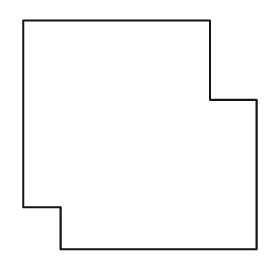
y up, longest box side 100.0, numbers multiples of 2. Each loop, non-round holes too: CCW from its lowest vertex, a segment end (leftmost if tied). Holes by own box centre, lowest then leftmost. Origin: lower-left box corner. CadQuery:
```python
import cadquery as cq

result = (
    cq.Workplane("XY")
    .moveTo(16.0, 0.0)
    .lineTo(100.0, 0.0)
    .lineTo(100.0, 64.0)
    .lineTo(80.0, 64.0)
    .lineTo(80.0, 98.0)
    .lineTo(0.0, 98.0)
    .lineTo(0.0, 18.0)
    .lineTo(16.0, 18.0)
    .close()
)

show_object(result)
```